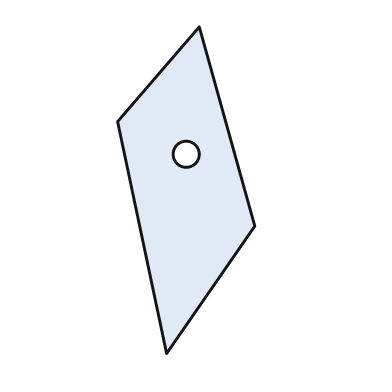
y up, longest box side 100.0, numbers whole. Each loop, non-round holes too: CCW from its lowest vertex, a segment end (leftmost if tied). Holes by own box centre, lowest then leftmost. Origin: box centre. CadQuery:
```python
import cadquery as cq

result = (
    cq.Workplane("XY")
    .moveTo(-6.0, -50.0)
    .lineTo(21.0, -11.0)
    .lineTo(4.0, 50.0)
    .lineTo(-21.0, 21.0)
    .close()
    .moveTo(0.0, 11.0)
    .circle(4.0)
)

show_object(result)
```